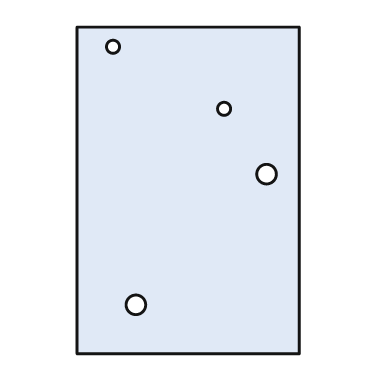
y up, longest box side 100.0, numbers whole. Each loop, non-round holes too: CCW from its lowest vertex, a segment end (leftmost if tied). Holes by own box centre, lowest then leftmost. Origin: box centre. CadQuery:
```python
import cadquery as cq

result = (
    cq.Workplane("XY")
    .moveTo(-34.0, -50.0)
    .lineTo(34.0, -50.0)
    .lineTo(34.0, 50.0)
    .lineTo(-34.0, 50.0)
    .close()
    .moveTo(-16.0, -35.0)
    .circle(3.0)
    .moveTo(24.0, 5.0)
    .circle(3.0)
    .moveTo(11.0, 25.0)
    .circle(2.0)
    .moveTo(-23.0, 44.0)
    .circle(2.0)
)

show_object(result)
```